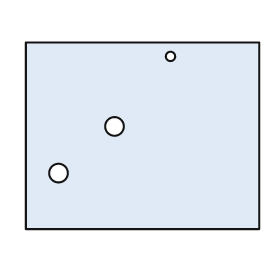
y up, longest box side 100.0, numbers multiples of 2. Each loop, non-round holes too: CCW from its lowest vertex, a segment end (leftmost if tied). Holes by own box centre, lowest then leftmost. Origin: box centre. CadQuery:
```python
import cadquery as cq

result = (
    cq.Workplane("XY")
    .moveTo(-50.0, -40.0)
    .lineTo(50.0, -40.0)
    .lineTo(50.0, 40.0)
    .lineTo(-50.0, 40.0)
    .close()
    .moveTo(-36.0, -16.0)
    .circle(4.0)
    .moveTo(-12.0, 4.0)
    .circle(4.0)
    .moveTo(12.0, 34.0)
    .circle(2.0)
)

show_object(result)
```